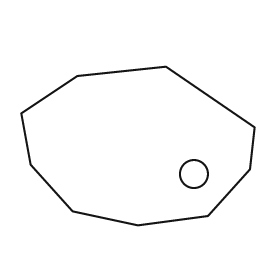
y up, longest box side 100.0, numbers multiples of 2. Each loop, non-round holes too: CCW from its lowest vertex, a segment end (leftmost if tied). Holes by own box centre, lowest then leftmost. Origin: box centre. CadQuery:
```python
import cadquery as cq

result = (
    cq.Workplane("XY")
    .moveTo(0.0, -34.0)
    .lineTo(30.0, -30.0)
    .lineTo(48.0, -10.0)
    .lineTo(50.0, 8.0)
    .lineTo(12.0, 34.0)
    .lineTo(-26.0, 30.0)
    .lineTo(-50.0, 14.0)
    .lineTo(-46.0, -8.0)
    .lineTo(-28.0, -28.0)
    .close()
    .moveTo(24.0, -12.0)
    .circle(6.0)
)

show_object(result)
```